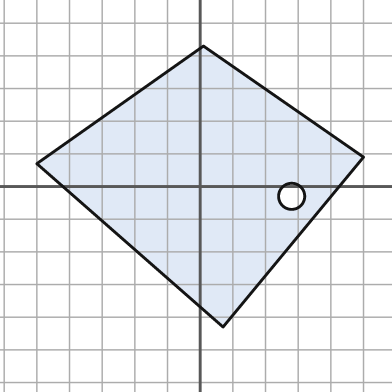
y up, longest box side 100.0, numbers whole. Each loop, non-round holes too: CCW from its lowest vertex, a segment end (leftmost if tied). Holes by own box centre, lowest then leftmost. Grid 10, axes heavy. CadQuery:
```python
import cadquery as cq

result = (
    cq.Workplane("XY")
    .moveTo(7.0, -43.0)
    .lineTo(50.0, 9.0)
    .lineTo(1.0, 43.0)
    .lineTo(-50.0, 7.0)
    .close()
    .moveTo(28.0, -3.0)
    .circle(4.0)
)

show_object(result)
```